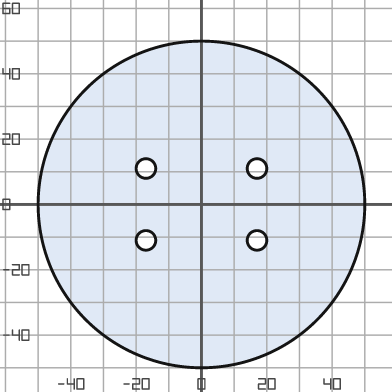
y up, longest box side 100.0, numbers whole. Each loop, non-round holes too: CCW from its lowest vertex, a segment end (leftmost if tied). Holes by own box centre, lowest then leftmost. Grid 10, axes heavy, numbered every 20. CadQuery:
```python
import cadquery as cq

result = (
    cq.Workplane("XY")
    .moveTo(0.0, 0.0)
    .circle(50.0)
    .moveTo(-17.0, -11.0)
    .circle(3.0)
    .moveTo(17.0, -11.0)
    .circle(3.0)
    .moveTo(-17.0, 11.0)
    .circle(3.0)
    .moveTo(17.0, 11.0)
    .circle(3.0)
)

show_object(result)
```